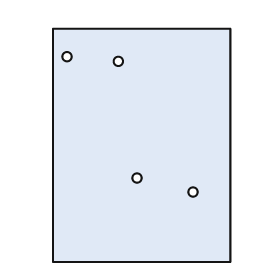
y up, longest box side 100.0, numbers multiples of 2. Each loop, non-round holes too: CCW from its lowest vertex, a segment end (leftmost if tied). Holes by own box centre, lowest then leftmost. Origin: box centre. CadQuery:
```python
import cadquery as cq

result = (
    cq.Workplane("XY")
    .moveTo(-38.0, -50.0)
    .lineTo(38.0, -50.0)
    .lineTo(38.0, 50.0)
    .lineTo(-38.0, 50.0)
    .close()
    .moveTo(22.0, -20.0)
    .circle(2.0)
    .moveTo(-2.0, -14.0)
    .circle(2.0)
    .moveTo(-10.0, 36.0)
    .circle(2.0)
    .moveTo(-32.0, 38.0)
    .circle(2.0)
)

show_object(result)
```